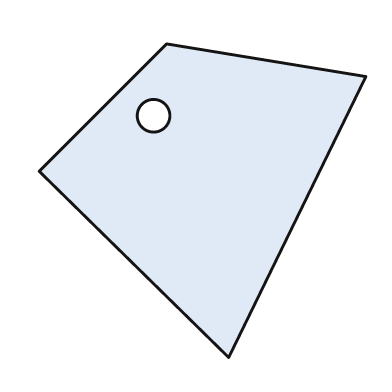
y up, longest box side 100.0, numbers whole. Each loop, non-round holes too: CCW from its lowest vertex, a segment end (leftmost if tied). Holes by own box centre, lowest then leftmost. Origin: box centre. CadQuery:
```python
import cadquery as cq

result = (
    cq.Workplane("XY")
    .moveTo(8.0, -48.0)
    .lineTo(50.0, 38.0)
    .lineTo(-11.0, 48.0)
    .lineTo(-50.0, 9.0)
    .close()
    .moveTo(-15.0, 26.0)
    .circle(5.0)
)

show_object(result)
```